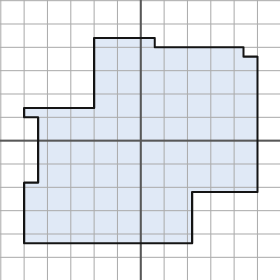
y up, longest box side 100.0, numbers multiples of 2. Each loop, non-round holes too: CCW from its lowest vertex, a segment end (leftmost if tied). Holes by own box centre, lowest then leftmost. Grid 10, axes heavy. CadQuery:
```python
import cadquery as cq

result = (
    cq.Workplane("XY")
    .moveTo(-50.0, -44.0)
    .lineTo(22.0, -44.0)
    .lineTo(22.0, -22.0)
    .lineTo(50.0, -22.0)
    .lineTo(50.0, 36.0)
    .lineTo(44.0, 36.0)
    .lineTo(44.0, 40.0)
    .lineTo(6.0, 40.0)
    .lineTo(6.0, 44.0)
    .lineTo(-20.0, 44.0)
    .lineTo(-20.0, 14.0)
    .lineTo(-50.0, 14.0)
    .lineTo(-50.0, 10.0)
    .lineTo(-44.0, 10.0)
    .lineTo(-44.0, -18.0)
    .lineTo(-50.0, -18.0)
    .close()
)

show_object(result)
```